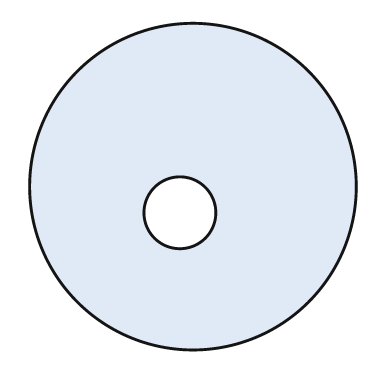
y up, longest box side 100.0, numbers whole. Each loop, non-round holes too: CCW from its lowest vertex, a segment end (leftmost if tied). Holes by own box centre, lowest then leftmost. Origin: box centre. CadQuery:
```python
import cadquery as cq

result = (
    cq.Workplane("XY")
    .moveTo(0.0, 0.0)
    .circle(50.0)
    .moveTo(-4.0, -8.0)
    .circle(11.0)
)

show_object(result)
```